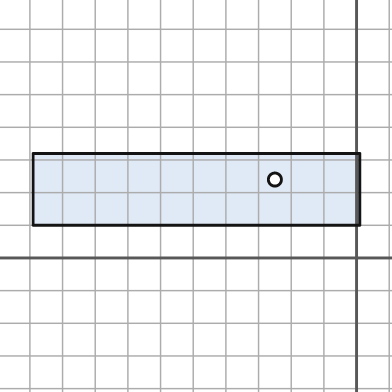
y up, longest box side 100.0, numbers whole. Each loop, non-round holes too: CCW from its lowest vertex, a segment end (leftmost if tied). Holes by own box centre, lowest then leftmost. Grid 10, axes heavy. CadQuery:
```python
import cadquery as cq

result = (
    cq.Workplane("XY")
    .moveTo(-99.0, 10.0)
    .lineTo(1.0, 10.0)
    .lineTo(1.0, 32.0)
    .lineTo(-99.0, 32.0)
    .close()
    .moveTo(-25.0, 24.0)
    .circle(2.0)
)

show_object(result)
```